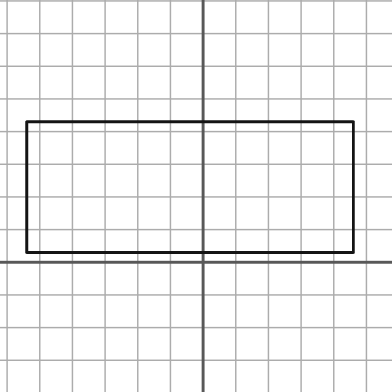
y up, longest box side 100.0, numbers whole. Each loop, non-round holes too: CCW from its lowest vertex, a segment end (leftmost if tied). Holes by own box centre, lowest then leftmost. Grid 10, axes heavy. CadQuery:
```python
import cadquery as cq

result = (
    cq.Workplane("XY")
    .moveTo(-54.0, 3.0)
    .lineTo(46.0, 3.0)
    .lineTo(46.0, 43.0)
    .lineTo(-54.0, 43.0)
    .close()
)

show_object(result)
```